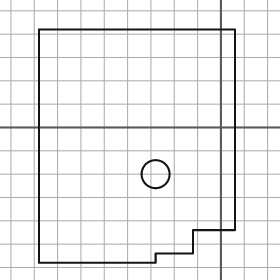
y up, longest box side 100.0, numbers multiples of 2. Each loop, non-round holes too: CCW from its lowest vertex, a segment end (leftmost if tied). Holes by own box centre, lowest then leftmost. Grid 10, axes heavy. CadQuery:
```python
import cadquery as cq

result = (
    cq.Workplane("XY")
    .moveTo(-78.0, -58.0)
    .lineTo(-28.0, -58.0)
    .lineTo(-28.0, -54.0)
    .lineTo(-12.0, -54.0)
    .lineTo(-12.0, -44.0)
    .lineTo(6.0, -44.0)
    .lineTo(6.0, 42.0)
    .lineTo(-78.0, 42.0)
    .close()
    .moveTo(-28.0, -20.0)
    .circle(6.0)
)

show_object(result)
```